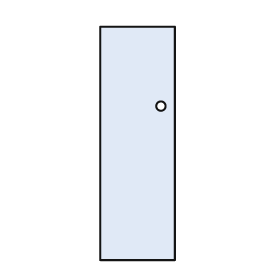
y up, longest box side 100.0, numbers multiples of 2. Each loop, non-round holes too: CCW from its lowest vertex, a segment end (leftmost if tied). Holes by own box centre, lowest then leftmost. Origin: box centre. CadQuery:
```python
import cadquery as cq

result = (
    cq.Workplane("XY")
    .moveTo(-16.0, -50.0)
    .lineTo(16.0, -50.0)
    .lineTo(16.0, 50.0)
    .lineTo(-16.0, 50.0)
    .close()
    .moveTo(10.0, 16.0)
    .circle(2.0)
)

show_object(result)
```